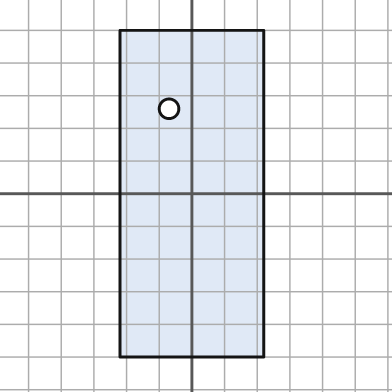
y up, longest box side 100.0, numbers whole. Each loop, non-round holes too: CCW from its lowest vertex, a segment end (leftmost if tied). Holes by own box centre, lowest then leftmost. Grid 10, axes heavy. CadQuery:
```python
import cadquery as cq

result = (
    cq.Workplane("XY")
    .moveTo(-22.0, -50.0)
    .lineTo(22.0, -50.0)
    .lineTo(22.0, 50.0)
    .lineTo(-22.0, 50.0)
    .close()
    .moveTo(-7.0, 26.0)
    .circle(3.0)
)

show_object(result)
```